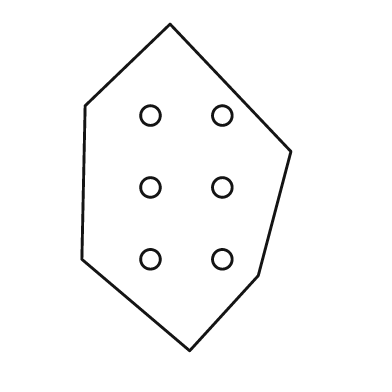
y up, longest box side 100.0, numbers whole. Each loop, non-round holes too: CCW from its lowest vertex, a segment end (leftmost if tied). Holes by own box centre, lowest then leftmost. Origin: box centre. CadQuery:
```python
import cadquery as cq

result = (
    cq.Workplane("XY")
    .moveTo(1.0, -50.0)
    .lineTo(22.0, -27.0)
    .lineTo(32.0, 11.0)
    .lineTo(-5.0, 50.0)
    .lineTo(-31.0, 25.0)
    .lineTo(-32.0, -22.0)
    .close()
    .moveTo(-11.0, -22.0)
    .circle(3.0)
    .moveTo(11.0, -22.0)
    .circle(3.0)
    .moveTo(-11.0, 0.0)
    .circle(3.0)
    .moveTo(11.0, 0.0)
    .circle(3.0)
    .moveTo(-11.0, 22.0)
    .circle(3.0)
    .moveTo(11.0, 22.0)
    .circle(3.0)
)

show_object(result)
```